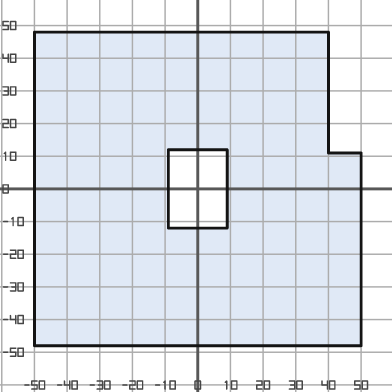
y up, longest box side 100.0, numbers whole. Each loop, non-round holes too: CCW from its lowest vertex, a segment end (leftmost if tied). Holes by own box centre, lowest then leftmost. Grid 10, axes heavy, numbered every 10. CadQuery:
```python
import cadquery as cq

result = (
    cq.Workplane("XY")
    .moveTo(-50.0, -48.0)
    .lineTo(50.0, -48.0)
    .lineTo(50.0, 11.0)
    .lineTo(40.0, 11.0)
    .lineTo(40.0, 48.0)
    .lineTo(-50.0, 48.0)
    .close()
    .moveTo(-9.0, -12.0)
    .lineTo(9.0, -12.0)
    .lineTo(9.0, 12.0)
    .lineTo(-9.0, 12.0)
    .close()
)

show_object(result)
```